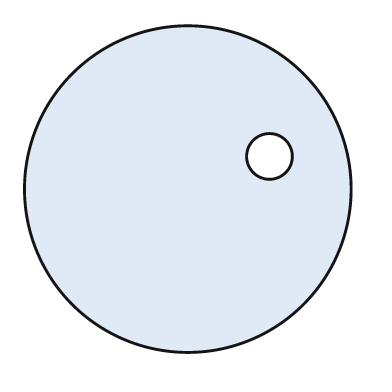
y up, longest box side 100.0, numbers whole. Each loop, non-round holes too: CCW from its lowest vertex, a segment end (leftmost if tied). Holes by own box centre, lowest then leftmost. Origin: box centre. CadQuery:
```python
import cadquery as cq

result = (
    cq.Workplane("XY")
    .moveTo(0.0, 0.0)
    .circle(50.0)
    .moveTo(25.0, 10.0)
    .circle(7.0)
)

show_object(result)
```